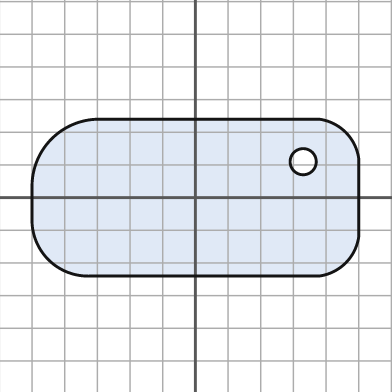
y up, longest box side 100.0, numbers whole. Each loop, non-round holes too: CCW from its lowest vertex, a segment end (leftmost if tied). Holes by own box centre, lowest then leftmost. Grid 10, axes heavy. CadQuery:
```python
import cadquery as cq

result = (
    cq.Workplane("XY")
    .moveTo(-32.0, -24.0)
    .lineTo(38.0, -24.0)
    .threePointArc((46.0, -20.0), (50.0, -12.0))
    .lineTo(50.0, 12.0)
    .threePointArc((46.0, 20.0), (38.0, 24.0))
    .lineTo(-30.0, 24.0)
    .threePointArc((-44.0, 18.0), (-50.0, 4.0))
    .lineTo(-50.0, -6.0)
    .threePointArc((-45.0, -19.0), (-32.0, -24.0))
    .close()
    .moveTo(33.0, 11.0)
    .circle(4.0)
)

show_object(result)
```